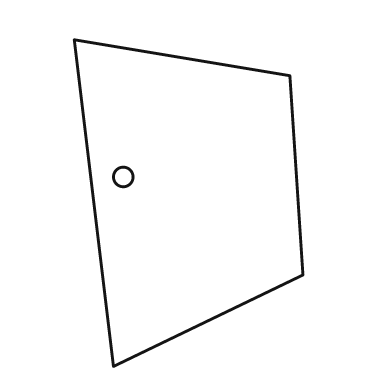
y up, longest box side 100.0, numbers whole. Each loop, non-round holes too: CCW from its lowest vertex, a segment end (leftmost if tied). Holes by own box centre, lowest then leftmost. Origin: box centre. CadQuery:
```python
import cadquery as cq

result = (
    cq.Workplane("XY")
    .moveTo(-23.0, -50.0)
    .lineTo(35.0, -22.0)
    .lineTo(31.0, 39.0)
    .lineTo(-35.0, 50.0)
    .close()
    .moveTo(-20.0, 8.0)
    .circle(3.0)
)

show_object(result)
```